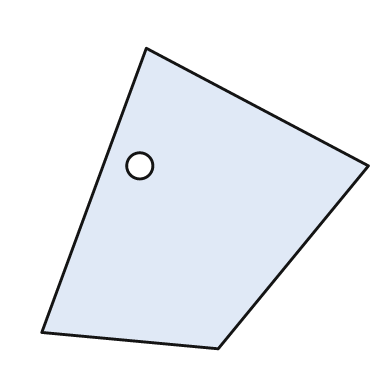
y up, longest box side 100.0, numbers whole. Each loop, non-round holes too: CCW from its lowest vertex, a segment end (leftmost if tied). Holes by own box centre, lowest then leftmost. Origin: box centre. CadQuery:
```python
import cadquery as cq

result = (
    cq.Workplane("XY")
    .moveTo(4.0, -46.0)
    .lineTo(50.0, 10.0)
    .lineTo(-18.0, 46.0)
    .lineTo(-50.0, -41.0)
    .close()
    .moveTo(-20.0, 10.0)
    .circle(4.0)
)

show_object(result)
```